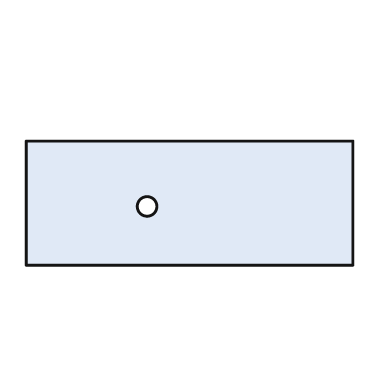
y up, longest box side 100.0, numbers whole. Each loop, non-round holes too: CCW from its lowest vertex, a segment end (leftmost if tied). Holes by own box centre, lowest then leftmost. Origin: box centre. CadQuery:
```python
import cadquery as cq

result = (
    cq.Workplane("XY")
    .moveTo(-50.0, -19.0)
    .lineTo(50.0, -19.0)
    .lineTo(50.0, 19.0)
    .lineTo(-50.0, 19.0)
    .close()
    .moveTo(-13.0, -1.0)
    .circle(3.0)
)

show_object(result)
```